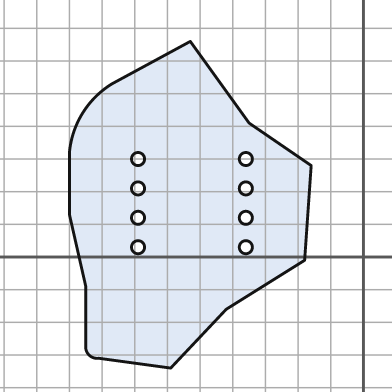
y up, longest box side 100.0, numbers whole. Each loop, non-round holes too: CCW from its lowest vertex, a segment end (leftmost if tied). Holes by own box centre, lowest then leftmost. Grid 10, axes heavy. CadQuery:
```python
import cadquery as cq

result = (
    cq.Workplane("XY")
    .moveTo(-59.0, -34.0)
    .lineTo(-42.0, -16.0)
    .lineTo(-18.0, -1.0)
    .lineTo(-16.0, 28.0)
    .lineTo(-35.0, 41.0)
    .lineTo(-53.0, 66.0)
    .lineTo(-77.0, 53.0)
    .threePointArc((-86.0, 44.0), (-90.0, 32.0))
    .lineTo(-90.0, 13.0)
    .lineTo(-85.0, -9.0)
    .lineTo(-85.0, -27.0)
    .threePointArc((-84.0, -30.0), (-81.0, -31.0))
    .close()
    .moveTo(-69.0, 3.0)
    .circle(2.0)
    .moveTo(-36.0, 3.0)
    .circle(2.0)
    .moveTo(-69.0, 12.0)
    .circle(2.0)
    .moveTo(-36.0, 12.0)
    .circle(2.0)
    .moveTo(-69.0, 21.0)
    .circle(2.0)
    .moveTo(-36.0, 21.0)
    .circle(2.0)
    .moveTo(-69.0, 30.0)
    .circle(2.0)
    .moveTo(-36.0, 30.0)
    .circle(2.0)
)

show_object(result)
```